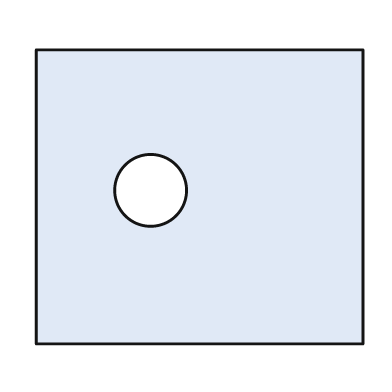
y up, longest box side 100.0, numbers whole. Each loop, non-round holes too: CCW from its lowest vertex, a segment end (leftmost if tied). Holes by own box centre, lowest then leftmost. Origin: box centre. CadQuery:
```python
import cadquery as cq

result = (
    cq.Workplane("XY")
    .moveTo(-50.0, -45.0)
    .lineTo(50.0, -45.0)
    .lineTo(50.0, 45.0)
    .lineTo(-50.0, 45.0)
    .close()
    .moveTo(-15.0, 2.0)
    .circle(11.0)
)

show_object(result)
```